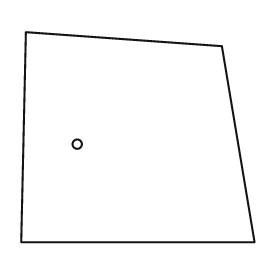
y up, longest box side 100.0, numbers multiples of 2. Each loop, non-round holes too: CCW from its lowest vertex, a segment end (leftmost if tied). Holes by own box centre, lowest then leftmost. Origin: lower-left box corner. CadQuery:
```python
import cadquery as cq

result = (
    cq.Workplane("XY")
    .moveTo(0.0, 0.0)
    .lineTo(100.0, 0.0)
    .lineTo(86.0, 84.0)
    .lineTo(2.0, 90.0)
    .close()
    .moveTo(24.0, 42.0)
    .circle(2.0)
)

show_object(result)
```